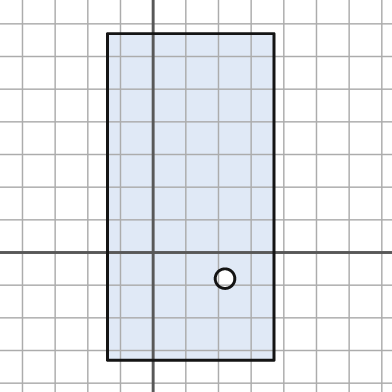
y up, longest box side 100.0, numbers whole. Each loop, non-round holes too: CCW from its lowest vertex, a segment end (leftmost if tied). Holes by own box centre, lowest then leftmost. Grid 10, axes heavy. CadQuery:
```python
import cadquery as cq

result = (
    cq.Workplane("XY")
    .moveTo(-14.0, -33.0)
    .lineTo(37.0, -33.0)
    .lineTo(37.0, 67.0)
    .lineTo(-14.0, 67.0)
    .close()
    .moveTo(22.0, -8.0)
    .circle(3.0)
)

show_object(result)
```